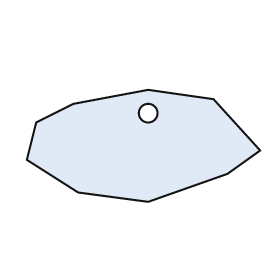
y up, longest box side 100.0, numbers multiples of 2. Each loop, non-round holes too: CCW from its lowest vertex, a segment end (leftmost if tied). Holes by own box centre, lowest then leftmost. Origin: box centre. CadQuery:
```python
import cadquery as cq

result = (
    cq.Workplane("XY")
    .moveTo(2.0, -24.0)
    .lineTo(36.0, -12.0)
    .lineTo(50.0, -2.0)
    .lineTo(30.0, 20.0)
    .lineTo(2.0, 24.0)
    .lineTo(-30.0, 18.0)
    .lineTo(-46.0, 10.0)
    .lineTo(-50.0, -6.0)
    .lineTo(-28.0, -20.0)
    .close()
    .moveTo(2.0, 14.0)
    .circle(4.0)
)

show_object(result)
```